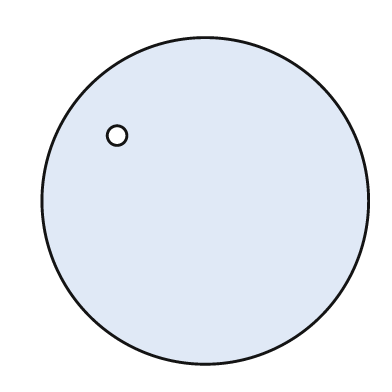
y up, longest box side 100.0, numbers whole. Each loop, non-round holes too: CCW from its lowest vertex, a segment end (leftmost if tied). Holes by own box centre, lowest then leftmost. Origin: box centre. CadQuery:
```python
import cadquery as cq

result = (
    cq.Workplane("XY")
    .moveTo(0.0, 0.0)
    .circle(50.0)
    .moveTo(-27.0, 20.0)
    .circle(3.0)
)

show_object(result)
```